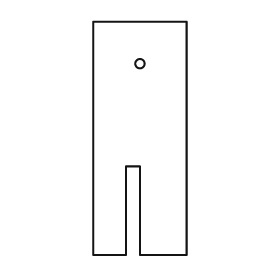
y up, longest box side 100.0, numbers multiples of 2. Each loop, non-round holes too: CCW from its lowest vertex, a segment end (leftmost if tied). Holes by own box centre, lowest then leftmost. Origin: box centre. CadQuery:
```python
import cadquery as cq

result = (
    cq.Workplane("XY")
    .moveTo(-20.0, -50.0)
    .lineTo(-6.0, -50.0)
    .lineTo(-6.0, -12.0)
    .lineTo(0.0, -12.0)
    .lineTo(0.0, -50.0)
    .lineTo(20.0, -50.0)
    .lineTo(20.0, 50.0)
    .lineTo(-20.0, 50.0)
    .close()
    .moveTo(0.0, 32.0)
    .circle(2.0)
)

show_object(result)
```